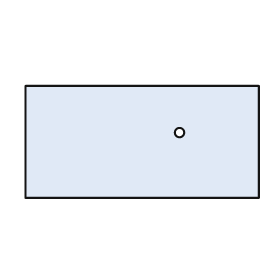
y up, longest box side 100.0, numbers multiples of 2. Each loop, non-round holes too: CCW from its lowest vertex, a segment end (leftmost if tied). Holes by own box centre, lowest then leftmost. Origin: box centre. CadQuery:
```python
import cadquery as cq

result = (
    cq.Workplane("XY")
    .moveTo(-50.0, -24.0)
    .lineTo(50.0, -24.0)
    .lineTo(50.0, 24.0)
    .lineTo(-50.0, 24.0)
    .close()
    .moveTo(16.0, 4.0)
    .circle(2.0)
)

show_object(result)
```